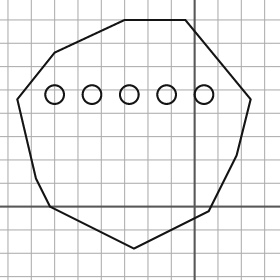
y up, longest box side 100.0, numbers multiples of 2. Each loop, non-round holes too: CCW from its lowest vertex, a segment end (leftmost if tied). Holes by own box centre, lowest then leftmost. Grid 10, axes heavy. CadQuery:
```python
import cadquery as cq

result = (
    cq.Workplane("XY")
    .moveTo(-26.0, -18.0)
    .lineTo(6.0, -2.0)
    .lineTo(18.0, 22.0)
    .lineTo(24.0, 46.0)
    .lineTo(-4.0, 80.0)
    .lineTo(-30.0, 80.0)
    .lineTo(-60.0, 66.0)
    .lineTo(-76.0, 46.0)
    .lineTo(-68.0, 12.0)
    .lineTo(-62.0, 0.0)
    .close()
    .moveTo(-60.0, 48.0)
    .circle(4.0)
    .moveTo(-44.0, 48.0)
    .circle(4.0)
    .moveTo(-28.0, 48.0)
    .circle(4.0)
    .moveTo(-12.0, 48.0)
    .circle(4.0)
    .moveTo(4.0, 48.0)
    .circle(4.0)
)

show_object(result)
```